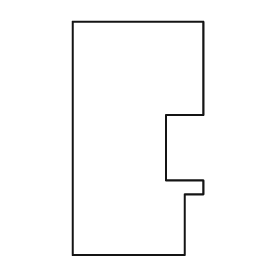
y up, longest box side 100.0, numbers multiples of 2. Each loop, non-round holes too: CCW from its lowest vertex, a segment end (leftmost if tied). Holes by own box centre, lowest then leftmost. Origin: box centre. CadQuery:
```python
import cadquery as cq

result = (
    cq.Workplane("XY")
    .moveTo(-28.0, -50.0)
    .lineTo(20.0, -50.0)
    .lineTo(20.0, -24.0)
    .lineTo(28.0, -24.0)
    .lineTo(28.0, -18.0)
    .lineTo(12.0, -18.0)
    .lineTo(12.0, 10.0)
    .lineTo(28.0, 10.0)
    .lineTo(28.0, 50.0)
    .lineTo(-28.0, 50.0)
    .close()
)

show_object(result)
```